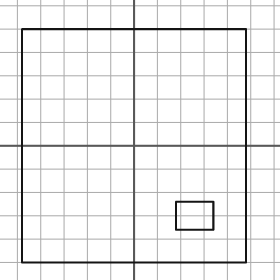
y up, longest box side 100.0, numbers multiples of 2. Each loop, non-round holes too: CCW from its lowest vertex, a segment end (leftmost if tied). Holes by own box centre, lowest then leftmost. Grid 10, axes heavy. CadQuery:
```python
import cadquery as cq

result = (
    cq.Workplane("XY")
    .moveTo(-48.0, -50.0)
    .lineTo(48.0, -50.0)
    .lineTo(48.0, 50.0)
    .lineTo(-48.0, 50.0)
    .close()
    .moveTo(18.0, -36.0)
    .lineTo(34.0, -36.0)
    .lineTo(34.0, -24.0)
    .lineTo(18.0, -24.0)
    .close()
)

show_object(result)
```